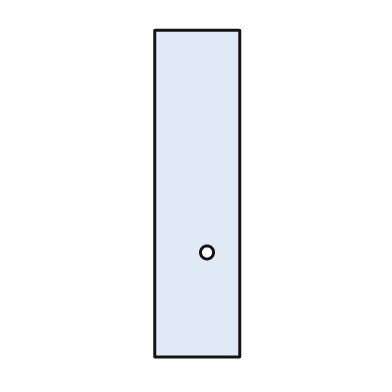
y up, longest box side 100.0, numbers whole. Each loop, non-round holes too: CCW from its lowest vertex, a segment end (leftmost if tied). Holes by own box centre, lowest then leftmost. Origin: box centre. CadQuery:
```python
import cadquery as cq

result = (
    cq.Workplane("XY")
    .moveTo(-13.0, -50.0)
    .lineTo(13.0, -50.0)
    .lineTo(13.0, 50.0)
    .lineTo(-13.0, 50.0)
    .close()
    .moveTo(3.0, -18.0)
    .circle(2.0)
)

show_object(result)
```